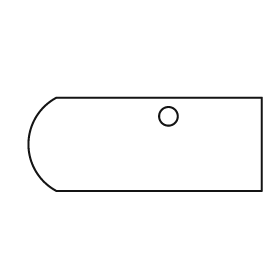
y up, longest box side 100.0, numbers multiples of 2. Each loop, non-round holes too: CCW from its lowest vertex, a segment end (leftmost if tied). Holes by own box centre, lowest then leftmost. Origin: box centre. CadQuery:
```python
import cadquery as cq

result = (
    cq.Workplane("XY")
    .moveTo(-38.0, -20.0)
    .lineTo(50.0, -20.0)
    .lineTo(50.0, 20.0)
    .lineTo(-38.0, 20.0)
    .threePointArc((-50.0, 0.0), (-38.0, -20.0))
    .close()
    .moveTo(10.0, 12.0)
    .circle(4.0)
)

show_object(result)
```